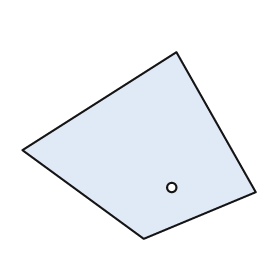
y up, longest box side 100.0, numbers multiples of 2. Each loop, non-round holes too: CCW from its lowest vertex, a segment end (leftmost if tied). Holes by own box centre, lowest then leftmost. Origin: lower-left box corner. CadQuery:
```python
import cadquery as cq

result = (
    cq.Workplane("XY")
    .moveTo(52.0, 0.0)
    .lineTo(100.0, 20.0)
    .lineTo(66.0, 80.0)
    .lineTo(0.0, 38.0)
    .close()
    .moveTo(64.0, 22.0)
    .circle(2.0)
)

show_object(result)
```